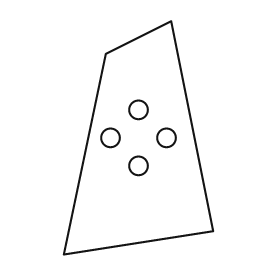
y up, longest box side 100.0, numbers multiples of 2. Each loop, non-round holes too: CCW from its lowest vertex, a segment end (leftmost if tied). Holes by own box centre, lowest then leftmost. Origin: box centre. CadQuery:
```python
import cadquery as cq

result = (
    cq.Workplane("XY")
    .moveTo(-32.0, -50.0)
    .lineTo(32.0, -40.0)
    .lineTo(14.0, 50.0)
    .lineTo(-14.0, 36.0)
    .close()
    .moveTo(0.0, -12.0)
    .circle(4.0)
    .moveTo(-12.0, 0.0)
    .circle(4.0)
    .moveTo(12.0, 0.0)
    .circle(4.0)
    .moveTo(0.0, 12.0)
    .circle(4.0)
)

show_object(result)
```